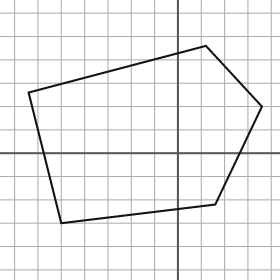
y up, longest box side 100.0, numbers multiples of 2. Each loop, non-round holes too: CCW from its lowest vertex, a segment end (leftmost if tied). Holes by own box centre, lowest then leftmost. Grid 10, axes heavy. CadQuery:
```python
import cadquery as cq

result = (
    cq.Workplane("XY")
    .moveTo(-50.0, -30.0)
    .lineTo(16.0, -22.0)
    .lineTo(36.0, 20.0)
    .lineTo(12.0, 46.0)
    .lineTo(-64.0, 26.0)
    .close()
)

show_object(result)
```